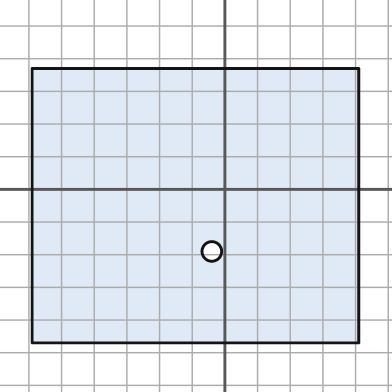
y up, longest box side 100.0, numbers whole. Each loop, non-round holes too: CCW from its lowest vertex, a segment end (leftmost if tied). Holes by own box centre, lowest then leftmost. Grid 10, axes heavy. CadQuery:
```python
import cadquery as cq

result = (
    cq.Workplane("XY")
    .moveTo(-59.0, -47.0)
    .lineTo(41.0, -47.0)
    .lineTo(41.0, 37.0)
    .lineTo(-59.0, 37.0)
    .close()
    .moveTo(-4.0, -19.0)
    .circle(3.0)
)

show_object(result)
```